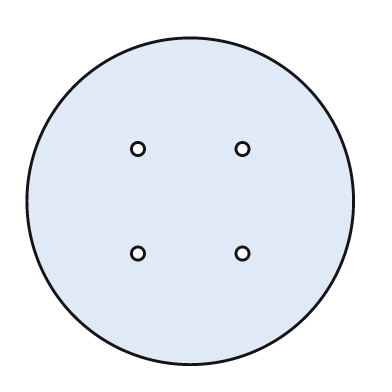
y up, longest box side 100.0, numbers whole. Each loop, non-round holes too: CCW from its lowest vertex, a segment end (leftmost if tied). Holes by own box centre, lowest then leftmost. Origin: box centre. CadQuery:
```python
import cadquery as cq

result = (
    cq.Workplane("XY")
    .moveTo(0.0, 0.0)
    .circle(50.0)
    .moveTo(-16.0, -16.0)
    .circle(2.0)
    .moveTo(16.0, -16.0)
    .circle(2.0)
    .moveTo(-16.0, 16.0)
    .circle(2.0)
    .moveTo(16.0, 16.0)
    .circle(2.0)
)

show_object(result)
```